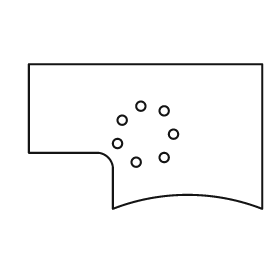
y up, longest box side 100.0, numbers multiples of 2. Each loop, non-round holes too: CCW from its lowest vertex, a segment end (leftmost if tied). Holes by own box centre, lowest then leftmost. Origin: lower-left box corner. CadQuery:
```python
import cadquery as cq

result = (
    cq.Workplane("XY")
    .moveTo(36.0, 0.0)
    .threePointArc((68.0, 6.0), (100.0, 0.0))
    .lineTo(100.0, 62.0)
    .lineTo(0.0, 62.0)
    .lineTo(0.0, 24.0)
    .lineTo(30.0, 24.0)
    .threePointArc((34.0, 22.0), (36.0, 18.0))
    .close()
    .moveTo(46.0, 20.0)
    .circle(2.0)
    .moveTo(58.0, 22.0)
    .circle(2.0)
    .moveTo(38.0, 28.0)
    .circle(2.0)
    .moveTo(62.0, 32.0)
    .circle(2.0)
    .moveTo(40.0, 38.0)
    .circle(2.0)
    .moveTo(58.0, 42.0)
    .circle(2.0)
    .moveTo(48.0, 44.0)
    .circle(2.0)
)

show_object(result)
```